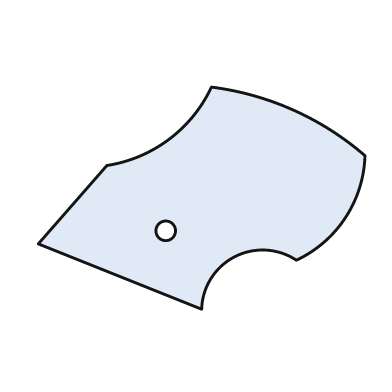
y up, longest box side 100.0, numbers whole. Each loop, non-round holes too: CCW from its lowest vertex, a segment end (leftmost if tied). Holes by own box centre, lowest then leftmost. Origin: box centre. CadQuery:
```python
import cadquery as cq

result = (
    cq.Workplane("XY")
    .moveTo(0.0, -34.0)
    .threePointArc((10.0, -18.0), (29.0, -19.0))
    .threePointArc((44.0, -6.0), (50.0, 13.0))
    .threePointArc((28.0, 27.0), (3.0, 34.0))
    .threePointArc((-10.0, 18.0), (-29.0, 10.0))
    .lineTo(-50.0, -14.0)
    .close()
    .moveTo(-11.0, -10.0)
    .circle(3.0)
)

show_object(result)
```